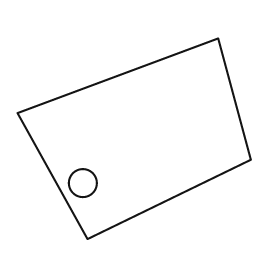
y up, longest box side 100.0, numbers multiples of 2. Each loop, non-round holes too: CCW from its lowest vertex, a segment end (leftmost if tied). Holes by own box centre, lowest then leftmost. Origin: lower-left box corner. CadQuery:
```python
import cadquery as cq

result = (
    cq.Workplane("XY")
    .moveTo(30.0, 0.0)
    .lineTo(100.0, 34.0)
    .lineTo(86.0, 86.0)
    .lineTo(0.0, 54.0)
    .close()
    .moveTo(28.0, 24.0)
    .circle(6.0)
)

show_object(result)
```